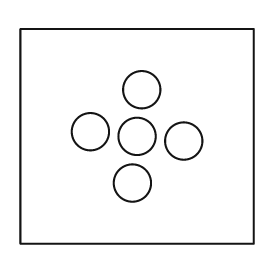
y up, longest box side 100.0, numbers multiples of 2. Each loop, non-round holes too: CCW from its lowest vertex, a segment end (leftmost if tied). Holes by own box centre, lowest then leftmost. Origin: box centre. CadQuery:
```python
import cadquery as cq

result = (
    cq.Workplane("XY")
    .moveTo(-50.0, -46.0)
    .lineTo(50.0, -46.0)
    .lineTo(50.0, 46.0)
    .lineTo(-50.0, 46.0)
    .close()
    .moveTo(-2.0, -20.0)
    .circle(8.0)
    .moveTo(20.0, -2.0)
    .circle(8.0)
    .moveTo(0.0, 0.0)
    .circle(8.0)
    .moveTo(-20.0, 2.0)
    .circle(8.0)
    .moveTo(2.0, 20.0)
    .circle(8.0)
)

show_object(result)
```